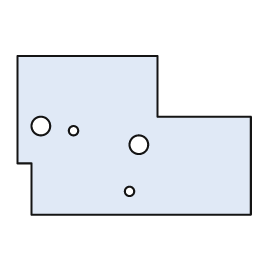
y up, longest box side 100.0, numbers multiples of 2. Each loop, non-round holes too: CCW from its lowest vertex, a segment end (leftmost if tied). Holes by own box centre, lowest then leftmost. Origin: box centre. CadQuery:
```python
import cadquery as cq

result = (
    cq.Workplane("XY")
    .moveTo(-44.0, -34.0)
    .lineTo(50.0, -34.0)
    .lineTo(50.0, 8.0)
    .lineTo(10.0, 8.0)
    .lineTo(10.0, 34.0)
    .lineTo(-50.0, 34.0)
    .lineTo(-50.0, -12.0)
    .lineTo(-44.0, -12.0)
    .close()
    .moveTo(-2.0, -24.0)
    .circle(2.0)
    .moveTo(2.0, -4.0)
    .circle(4.0)
    .moveTo(-26.0, 2.0)
    .circle(2.0)
    .moveTo(-40.0, 4.0)
    .circle(4.0)
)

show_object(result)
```